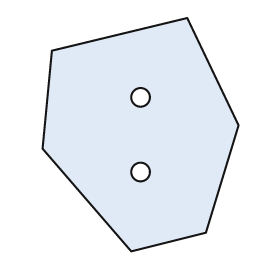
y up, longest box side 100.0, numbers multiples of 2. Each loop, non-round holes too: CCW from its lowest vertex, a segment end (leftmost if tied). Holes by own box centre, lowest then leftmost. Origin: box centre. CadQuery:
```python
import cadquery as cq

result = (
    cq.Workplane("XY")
    .moveTo(-4.0, -50.0)
    .lineTo(28.0, -42.0)
    .lineTo(42.0, 4.0)
    .lineTo(20.0, 50.0)
    .lineTo(-38.0, 36.0)
    .lineTo(-42.0, -6.0)
    .close()
    .moveTo(0.0, -16.0)
    .circle(4.0)
    .moveTo(0.0, 16.0)
    .circle(4.0)
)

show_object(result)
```